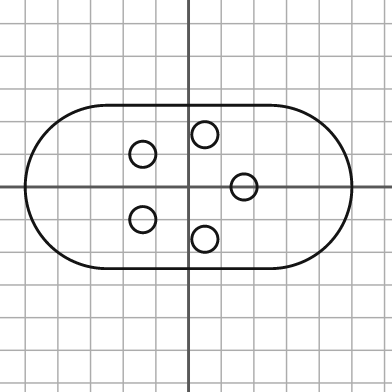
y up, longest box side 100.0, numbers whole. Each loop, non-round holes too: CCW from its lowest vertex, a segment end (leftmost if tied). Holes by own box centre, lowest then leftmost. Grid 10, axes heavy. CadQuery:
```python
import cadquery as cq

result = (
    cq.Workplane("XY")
    .moveTo(-25.0, -25.0)
    .lineTo(25.0, -25.0)
    .threePointArc((50.0, 0.0), (25.0, 25.0))
    .lineTo(-25.0, 25.0)
    .threePointArc((-50.0, 0.0), (-25.0, -25.0))
    .close()
    .moveTo(5.0, -16.0)
    .circle(4.0)
    .moveTo(-14.0, -10.0)
    .circle(4.0)
    .moveTo(17.0, 0.0)
    .circle(4.0)
    .moveTo(-14.0, 10.0)
    .circle(4.0)
    .moveTo(5.0, 16.0)
    .circle(4.0)
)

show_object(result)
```